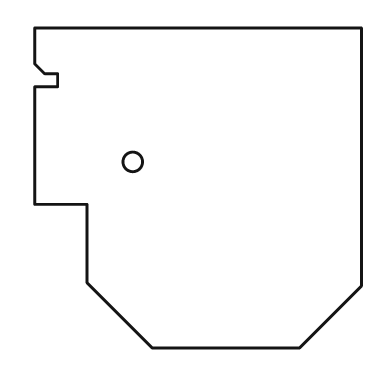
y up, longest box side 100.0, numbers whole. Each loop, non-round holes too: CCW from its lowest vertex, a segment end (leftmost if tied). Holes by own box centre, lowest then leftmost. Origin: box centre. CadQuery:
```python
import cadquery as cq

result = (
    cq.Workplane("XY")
    .moveTo(-14.0, -49.0)
    .lineTo(31.0, -49.0)
    .lineTo(50.0, -30.0)
    .lineTo(50.0, 49.0)
    .lineTo(-50.0, 49.0)
    .lineTo(-50.0, 38.0)
    .lineTo(-47.0, 35.0)
    .lineTo(-43.0, 35.0)
    .lineTo(-43.0, 31.0)
    .lineTo(-50.0, 31.0)
    .lineTo(-50.0, -5.0)
    .lineTo(-34.0, -5.0)
    .lineTo(-34.0, -29.0)
    .close()
    .moveTo(-20.0, 8.0)
    .circle(3.0)
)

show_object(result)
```